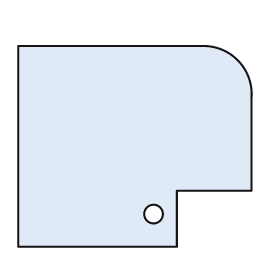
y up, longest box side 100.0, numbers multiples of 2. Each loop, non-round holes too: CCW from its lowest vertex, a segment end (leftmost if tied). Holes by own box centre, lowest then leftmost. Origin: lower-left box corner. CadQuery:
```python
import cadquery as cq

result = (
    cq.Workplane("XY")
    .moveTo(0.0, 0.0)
    .lineTo(68.0, 0.0)
    .lineTo(68.0, 24.0)
    .lineTo(100.0, 24.0)
    .lineTo(100.0, 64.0)
    .threePointArc((94.0, 80.0), (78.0, 86.0))
    .lineTo(0.0, 86.0)
    .close()
    .moveTo(58.0, 14.0)
    .circle(4.0)
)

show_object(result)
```